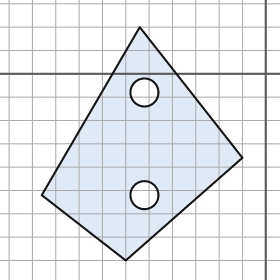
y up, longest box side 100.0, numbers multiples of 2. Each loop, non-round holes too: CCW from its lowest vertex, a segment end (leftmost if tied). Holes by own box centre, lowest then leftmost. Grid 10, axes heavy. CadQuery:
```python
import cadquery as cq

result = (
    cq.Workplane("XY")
    .moveTo(-60.0, -80.0)
    .lineTo(-10.0, -36.0)
    .lineTo(-54.0, 20.0)
    .lineTo(-96.0, -52.0)
    .close()
    .moveTo(-52.0, -52.0)
    .circle(6.0)
    .moveTo(-52.0, -8.0)
    .circle(6.0)
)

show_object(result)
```